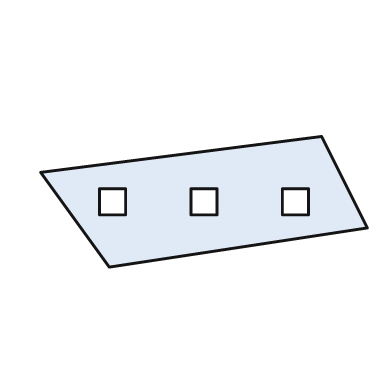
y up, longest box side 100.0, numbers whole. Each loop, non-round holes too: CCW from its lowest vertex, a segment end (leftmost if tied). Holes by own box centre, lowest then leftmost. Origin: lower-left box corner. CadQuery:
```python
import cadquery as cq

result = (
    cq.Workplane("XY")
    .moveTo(21.0, 0.0)
    .lineTo(100.0, 12.0)
    .lineTo(86.0, 40.0)
    .lineTo(0.0, 29.0)
    .close()
    .moveTo(18.0, 16.0)
    .lineTo(26.0, 16.0)
    .lineTo(26.0, 24.0)
    .lineTo(18.0, 24.0)
    .close()
    .moveTo(46.0, 16.0)
    .lineTo(54.0, 16.0)
    .lineTo(54.0, 24.0)
    .lineTo(46.0, 24.0)
    .close()
    .moveTo(74.0, 16.0)
    .lineTo(82.0, 16.0)
    .lineTo(82.0, 24.0)
    .lineTo(74.0, 24.0)
    .close()
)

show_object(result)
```